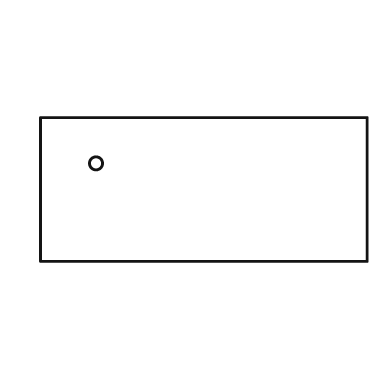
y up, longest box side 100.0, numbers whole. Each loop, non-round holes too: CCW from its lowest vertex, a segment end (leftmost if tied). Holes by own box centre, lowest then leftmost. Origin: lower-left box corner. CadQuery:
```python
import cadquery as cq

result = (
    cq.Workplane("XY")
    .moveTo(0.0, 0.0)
    .lineTo(100.0, 0.0)
    .lineTo(100.0, 44.0)
    .lineTo(0.0, 44.0)
    .close()
    .moveTo(17.0, 30.0)
    .circle(2.0)
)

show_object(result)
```